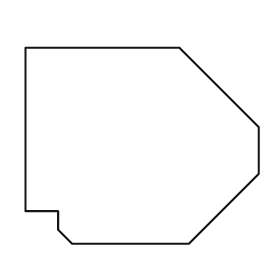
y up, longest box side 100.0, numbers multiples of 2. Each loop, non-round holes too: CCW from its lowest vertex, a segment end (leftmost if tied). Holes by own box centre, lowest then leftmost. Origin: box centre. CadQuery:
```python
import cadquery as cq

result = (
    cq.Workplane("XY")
    .moveTo(-30.0, -42.0)
    .lineTo(20.0, -42.0)
    .lineTo(50.0, -12.0)
    .lineTo(50.0, 8.0)
    .lineTo(16.0, 42.0)
    .lineTo(-50.0, 42.0)
    .lineTo(-50.0, -28.0)
    .lineTo(-36.0, -28.0)
    .lineTo(-36.0, -36.0)
    .close()
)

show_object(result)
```